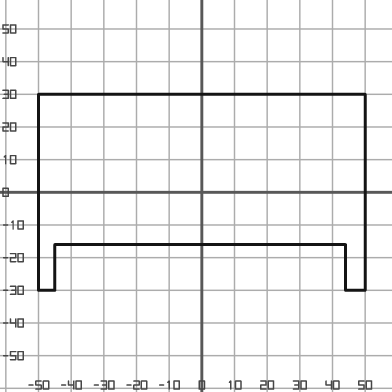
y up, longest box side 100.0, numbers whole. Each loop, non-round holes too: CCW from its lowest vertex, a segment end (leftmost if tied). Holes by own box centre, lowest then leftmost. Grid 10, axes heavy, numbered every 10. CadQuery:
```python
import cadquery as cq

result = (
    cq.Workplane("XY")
    .moveTo(-50.0, -30.0)
    .lineTo(-45.0, -30.0)
    .lineTo(-45.0, -16.0)
    .lineTo(44.0, -16.0)
    .lineTo(44.0, -30.0)
    .lineTo(50.0, -30.0)
    .lineTo(50.0, 30.0)
    .lineTo(-50.0, 30.0)
    .close()
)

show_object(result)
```